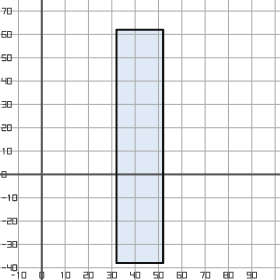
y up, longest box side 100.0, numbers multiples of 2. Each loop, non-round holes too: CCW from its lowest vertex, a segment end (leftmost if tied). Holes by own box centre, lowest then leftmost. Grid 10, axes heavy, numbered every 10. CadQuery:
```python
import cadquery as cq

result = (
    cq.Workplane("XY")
    .moveTo(32.0, -38.0)
    .lineTo(52.0, -38.0)
    .lineTo(52.0, 62.0)
    .lineTo(32.0, 62.0)
    .close()
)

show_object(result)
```